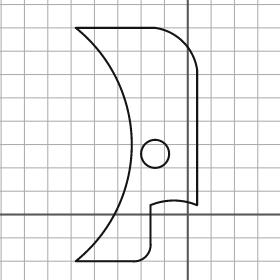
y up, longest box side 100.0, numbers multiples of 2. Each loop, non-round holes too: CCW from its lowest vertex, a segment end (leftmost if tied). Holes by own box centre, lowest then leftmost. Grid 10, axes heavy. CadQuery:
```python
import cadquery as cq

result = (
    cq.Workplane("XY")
    .moveTo(-48.0, -20.0)
    .lineTo(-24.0, -20.0)
    .threePointArc((-18.0, -18.0), (-16.0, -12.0))
    .lineTo(-16.0, 4.0)
    .threePointArc((-6.0, 6.0), (4.0, 4.0))
    .lineTo(4.0, 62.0)
    .threePointArc((-2.0, 74.0), (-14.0, 80.0))
    .lineTo(-48.0, 80.0)
    .threePointArc((-24.0, 30.0), (-48.0, -20.0))
    .close()
    .moveTo(-14.0, 26.0)
    .circle(6.0)
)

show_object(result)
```